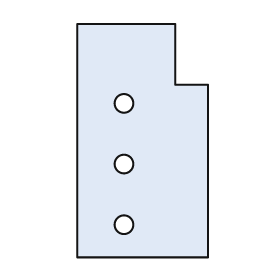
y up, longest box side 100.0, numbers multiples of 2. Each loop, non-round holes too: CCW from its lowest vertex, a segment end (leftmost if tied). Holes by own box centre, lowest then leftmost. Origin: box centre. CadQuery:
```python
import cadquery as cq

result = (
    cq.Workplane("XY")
    .moveTo(-28.0, -50.0)
    .lineTo(28.0, -50.0)
    .lineTo(28.0, 24.0)
    .lineTo(14.0, 24.0)
    .lineTo(14.0, 50.0)
    .lineTo(-28.0, 50.0)
    .close()
    .moveTo(-8.0, -36.0)
    .circle(4.0)
    .moveTo(-8.0, -10.0)
    .circle(4.0)
    .moveTo(-8.0, 16.0)
    .circle(4.0)
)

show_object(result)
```